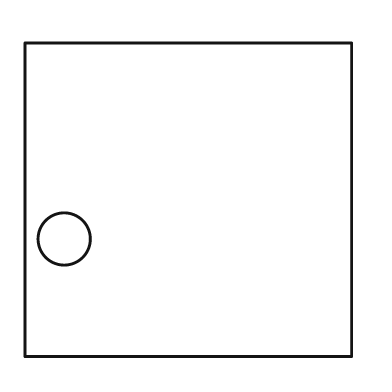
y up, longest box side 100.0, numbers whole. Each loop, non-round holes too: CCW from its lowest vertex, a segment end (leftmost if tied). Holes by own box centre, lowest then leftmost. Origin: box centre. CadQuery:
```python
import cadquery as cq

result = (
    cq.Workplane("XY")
    .moveTo(-50.0, -48.0)
    .lineTo(50.0, -48.0)
    .lineTo(50.0, 48.0)
    .lineTo(-50.0, 48.0)
    .close()
    .moveTo(-38.0, -12.0)
    .circle(8.0)
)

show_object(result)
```